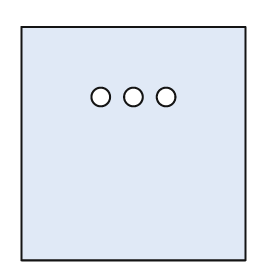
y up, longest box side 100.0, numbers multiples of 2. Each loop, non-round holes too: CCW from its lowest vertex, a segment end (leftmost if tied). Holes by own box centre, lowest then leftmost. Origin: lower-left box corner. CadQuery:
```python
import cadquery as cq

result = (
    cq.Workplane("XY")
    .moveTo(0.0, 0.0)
    .lineTo(96.0, 0.0)
    .lineTo(96.0, 100.0)
    .lineTo(0.0, 100.0)
    .close()
    .moveTo(34.0, 70.0)
    .circle(4.0)
    .moveTo(48.0, 70.0)
    .circle(4.0)
    .moveTo(62.0, 70.0)
    .circle(4.0)
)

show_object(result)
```